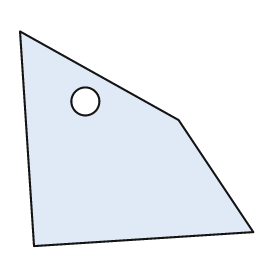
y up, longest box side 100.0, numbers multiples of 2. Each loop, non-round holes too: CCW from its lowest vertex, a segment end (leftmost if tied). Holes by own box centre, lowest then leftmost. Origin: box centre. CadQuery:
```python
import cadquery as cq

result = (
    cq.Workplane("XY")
    .moveTo(-44.0, -46.0)
    .lineTo(50.0, -40.0)
    .lineTo(18.0, 8.0)
    .lineTo(-50.0, 46.0)
    .close()
    .moveTo(-22.0, 16.0)
    .circle(6.0)
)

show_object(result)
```